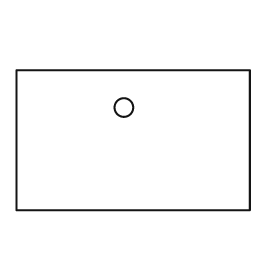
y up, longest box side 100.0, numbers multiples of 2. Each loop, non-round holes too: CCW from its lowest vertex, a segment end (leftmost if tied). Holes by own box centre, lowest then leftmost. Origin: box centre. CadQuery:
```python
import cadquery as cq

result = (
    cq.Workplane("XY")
    .moveTo(-50.0, -30.0)
    .lineTo(50.0, -30.0)
    .lineTo(50.0, 30.0)
    .lineTo(-50.0, 30.0)
    .close()
    .moveTo(-4.0, 14.0)
    .circle(4.0)
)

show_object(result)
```